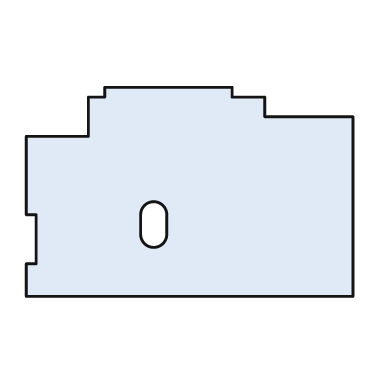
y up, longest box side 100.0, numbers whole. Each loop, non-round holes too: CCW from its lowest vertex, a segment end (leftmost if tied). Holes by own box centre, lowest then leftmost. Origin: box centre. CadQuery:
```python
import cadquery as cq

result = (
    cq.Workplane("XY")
    .moveTo(-50.0, -32.0)
    .lineTo(50.0, -32.0)
    .lineTo(50.0, 23.0)
    .lineTo(23.0, 23.0)
    .lineTo(23.0, 29.0)
    .lineTo(13.0, 29.0)
    .lineTo(13.0, 32.0)
    .lineTo(-26.0, 32.0)
    .lineTo(-26.0, 29.0)
    .lineTo(-31.0, 29.0)
    .lineTo(-31.0, 17.0)
    .lineTo(-50.0, 17.0)
    .lineTo(-50.0, -7.0)
    .lineTo(-47.0, -7.0)
    .lineTo(-47.0, -22.0)
    .lineTo(-50.0, -22.0)
    .close()
    .moveTo(-15.0, -13.0)
    .threePointArc((-11.0, -17.0), (-7.0, -13.0))
    .lineTo(-7.0, -7.0)
    .threePointArc((-11.0, -3.0), (-15.0, -7.0))
    .close()
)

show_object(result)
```